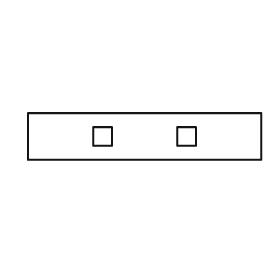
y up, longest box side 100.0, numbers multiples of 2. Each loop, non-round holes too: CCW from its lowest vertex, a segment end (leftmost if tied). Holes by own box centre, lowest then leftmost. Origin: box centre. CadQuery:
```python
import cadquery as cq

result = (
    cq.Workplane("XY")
    .moveTo(-50.0, -10.0)
    .lineTo(50.0, -10.0)
    .lineTo(50.0, 10.0)
    .lineTo(-50.0, 10.0)
    .close()
    .moveTo(-22.0, -4.0)
    .lineTo(-14.0, -4.0)
    .lineTo(-14.0, 4.0)
    .lineTo(-22.0, 4.0)
    .close()
    .moveTo(14.0, -4.0)
    .lineTo(22.0, -4.0)
    .lineTo(22.0, 4.0)
    .lineTo(14.0, 4.0)
    .close()
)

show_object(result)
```